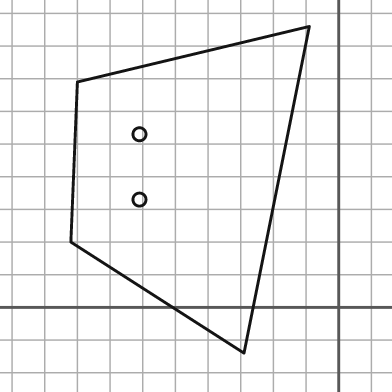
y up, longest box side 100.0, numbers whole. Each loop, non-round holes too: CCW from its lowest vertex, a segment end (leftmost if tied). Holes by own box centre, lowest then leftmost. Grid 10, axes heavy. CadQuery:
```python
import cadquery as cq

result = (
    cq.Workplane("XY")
    .moveTo(-29.0, -14.0)
    .lineTo(-9.0, 86.0)
    .lineTo(-80.0, 69.0)
    .lineTo(-82.0, 20.0)
    .close()
    .moveTo(-61.0, 33.0)
    .circle(2.0)
    .moveTo(-61.0, 53.0)
    .circle(2.0)
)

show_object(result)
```